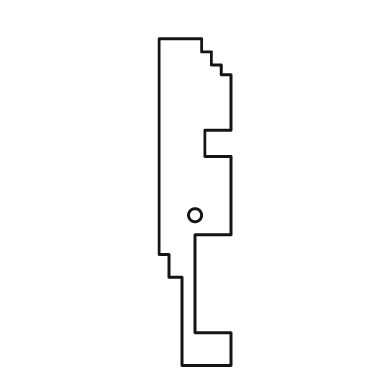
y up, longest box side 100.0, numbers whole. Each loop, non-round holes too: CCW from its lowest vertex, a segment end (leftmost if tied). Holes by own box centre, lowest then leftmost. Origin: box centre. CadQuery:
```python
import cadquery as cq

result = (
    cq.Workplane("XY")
    .moveTo(-4.0, -50.0)
    .lineTo(11.0, -50.0)
    .lineTo(11.0, -40.0)
    .lineTo(0.0, -40.0)
    .lineTo(0.0, -10.0)
    .lineTo(11.0, -10.0)
    .lineTo(11.0, 14.0)
    .lineTo(3.0, 14.0)
    .lineTo(3.0, 22.0)
    .lineTo(11.0, 22.0)
    .lineTo(11.0, 39.0)
    .lineTo(8.0, 39.0)
    .lineTo(8.0, 42.0)
    .lineTo(5.0, 42.0)
    .lineTo(5.0, 46.0)
    .lineTo(2.0, 46.0)
    .lineTo(2.0, 50.0)
    .lineTo(-11.0, 50.0)
    .lineTo(-11.0, -16.0)
    .lineTo(-8.0, -16.0)
    .lineTo(-8.0, -23.0)
    .lineTo(-4.0, -23.0)
    .close()
    .moveTo(0.0, -4.0)
    .circle(2.0)
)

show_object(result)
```